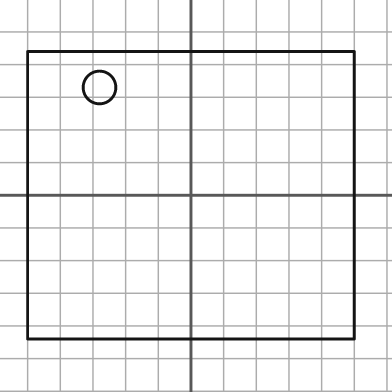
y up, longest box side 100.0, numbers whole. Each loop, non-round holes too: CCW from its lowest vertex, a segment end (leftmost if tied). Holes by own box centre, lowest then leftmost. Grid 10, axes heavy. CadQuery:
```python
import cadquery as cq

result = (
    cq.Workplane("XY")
    .moveTo(-50.0, -44.0)
    .lineTo(50.0, -44.0)
    .lineTo(50.0, 44.0)
    .lineTo(-50.0, 44.0)
    .close()
    .moveTo(-28.0, 33.0)
    .circle(5.0)
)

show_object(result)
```